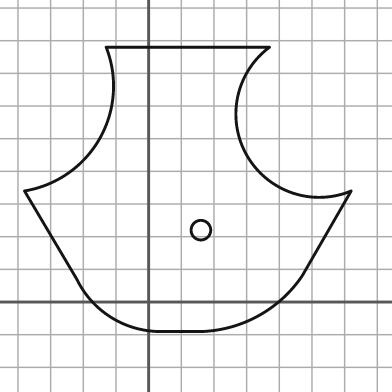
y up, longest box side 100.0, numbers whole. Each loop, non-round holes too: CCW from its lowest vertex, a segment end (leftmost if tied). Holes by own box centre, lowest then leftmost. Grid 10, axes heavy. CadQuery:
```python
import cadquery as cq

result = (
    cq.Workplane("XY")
    .moveTo(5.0, -9.0)
    .lineTo(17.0, -9.0)
    .threePointArc((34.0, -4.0), (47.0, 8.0))
    .lineTo(62.0, 34.0)
    .threePointArc((30.0, 45.0), (37.0, 78.0))
    .lineTo(-13.0, 78.0)
    .threePointArc((-15.0, 50.0), (-38.0, 34.0))
    .lineTo(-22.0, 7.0)
    .threePointArc((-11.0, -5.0), (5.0, -9.0))
    .close()
    .moveTo(16.0, 22.0)
    .circle(3.0)
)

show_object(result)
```